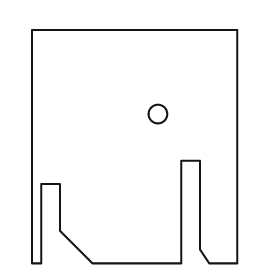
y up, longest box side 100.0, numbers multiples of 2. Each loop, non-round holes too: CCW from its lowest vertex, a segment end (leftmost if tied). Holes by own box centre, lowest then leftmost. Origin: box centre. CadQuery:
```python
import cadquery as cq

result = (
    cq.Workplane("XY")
    .moveTo(-44.0, -50.0)
    .lineTo(-40.0, -50.0)
    .lineTo(-40.0, -16.0)
    .lineTo(-32.0, -16.0)
    .lineTo(-32.0, -36.0)
    .lineTo(-18.0, -50.0)
    .lineTo(20.0, -50.0)
    .lineTo(20.0, -6.0)
    .lineTo(28.0, -6.0)
    .lineTo(28.0, -44.0)
    .lineTo(32.0, -50.0)
    .lineTo(44.0, -50.0)
    .lineTo(44.0, 50.0)
    .lineTo(-44.0, 50.0)
    .close()
    .moveTo(10.0, 14.0)
    .circle(4.0)
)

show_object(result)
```